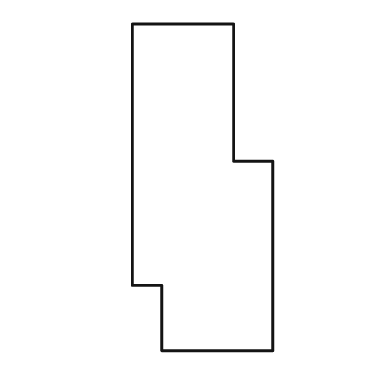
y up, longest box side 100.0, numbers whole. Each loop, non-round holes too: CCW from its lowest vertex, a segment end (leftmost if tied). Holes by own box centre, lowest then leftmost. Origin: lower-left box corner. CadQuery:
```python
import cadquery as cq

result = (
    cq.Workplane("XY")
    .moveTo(9.0, 0.0)
    .lineTo(43.0, 0.0)
    .lineTo(43.0, 58.0)
    .lineTo(31.0, 58.0)
    .lineTo(31.0, 100.0)
    .lineTo(0.0, 100.0)
    .lineTo(0.0, 20.0)
    .lineTo(9.0, 20.0)
    .close()
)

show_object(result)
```